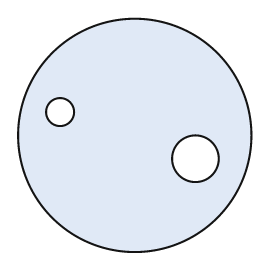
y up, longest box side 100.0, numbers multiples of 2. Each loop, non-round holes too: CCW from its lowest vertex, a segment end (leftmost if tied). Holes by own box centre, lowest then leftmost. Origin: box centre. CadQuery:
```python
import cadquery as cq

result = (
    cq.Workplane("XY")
    .moveTo(0.0, 0.0)
    .circle(50.0)
    .moveTo(26.0, -10.0)
    .circle(10.0)
    .moveTo(-32.0, 10.0)
    .circle(6.0)
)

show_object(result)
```